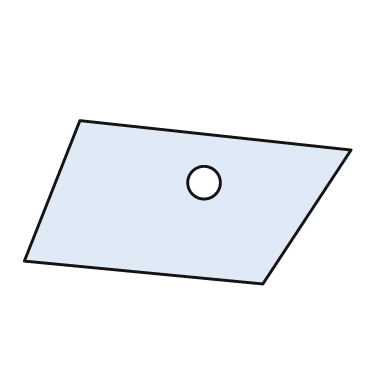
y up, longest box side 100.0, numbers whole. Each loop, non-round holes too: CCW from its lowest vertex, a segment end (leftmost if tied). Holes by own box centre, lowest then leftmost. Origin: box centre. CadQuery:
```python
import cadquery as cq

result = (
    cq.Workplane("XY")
    .moveTo(23.0, -25.0)
    .lineTo(50.0, 16.0)
    .lineTo(-33.0, 25.0)
    .lineTo(-50.0, -18.0)
    .close()
    .moveTo(5.0, 6.0)
    .circle(5.0)
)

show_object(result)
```